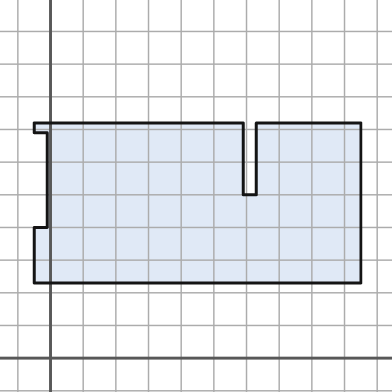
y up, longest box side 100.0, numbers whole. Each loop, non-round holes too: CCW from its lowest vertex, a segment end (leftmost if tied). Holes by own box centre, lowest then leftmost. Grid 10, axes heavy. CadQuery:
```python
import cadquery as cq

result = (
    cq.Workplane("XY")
    .moveTo(-5.0, 23.0)
    .lineTo(95.0, 23.0)
    .lineTo(95.0, 72.0)
    .lineTo(63.0, 72.0)
    .lineTo(63.0, 50.0)
    .lineTo(59.0, 50.0)
    .lineTo(59.0, 72.0)
    .lineTo(-5.0, 72.0)
    .lineTo(-5.0, 69.0)
    .lineTo(-1.0, 69.0)
    .lineTo(-1.0, 40.0)
    .lineTo(-5.0, 40.0)
    .close()
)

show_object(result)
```